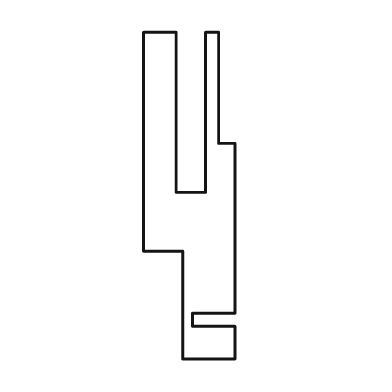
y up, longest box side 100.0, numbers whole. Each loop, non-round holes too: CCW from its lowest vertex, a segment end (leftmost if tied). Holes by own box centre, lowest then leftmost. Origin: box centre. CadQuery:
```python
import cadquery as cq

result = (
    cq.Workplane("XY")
    .moveTo(-2.0, -50.0)
    .lineTo(14.0, -50.0)
    .lineTo(14.0, -40.0)
    .lineTo(1.0, -40.0)
    .lineTo(1.0, -36.0)
    .lineTo(14.0, -36.0)
    .lineTo(14.0, 16.0)
    .lineTo(9.0, 16.0)
    .lineTo(9.0, 50.0)
    .lineTo(5.0, 50.0)
    .lineTo(5.0, 1.0)
    .lineTo(-4.0, 1.0)
    .lineTo(-4.0, 50.0)
    .lineTo(-14.0, 50.0)
    .lineTo(-14.0, -17.0)
    .lineTo(-2.0, -17.0)
    .close()
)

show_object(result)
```